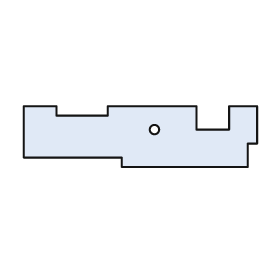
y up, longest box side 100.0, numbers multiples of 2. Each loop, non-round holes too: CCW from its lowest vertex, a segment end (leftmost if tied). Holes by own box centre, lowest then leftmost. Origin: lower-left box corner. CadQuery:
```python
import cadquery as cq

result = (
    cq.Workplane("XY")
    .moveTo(42.0, 0.0)
    .lineTo(96.0, 0.0)
    .lineTo(96.0, 10.0)
    .lineTo(100.0, 10.0)
    .lineTo(100.0, 26.0)
    .lineTo(88.0, 26.0)
    .lineTo(88.0, 16.0)
    .lineTo(74.0, 16.0)
    .lineTo(74.0, 26.0)
    .lineTo(36.0, 26.0)
    .lineTo(36.0, 22.0)
    .lineTo(14.0, 22.0)
    .lineTo(14.0, 26.0)
    .lineTo(0.0, 26.0)
    .lineTo(0.0, 4.0)
    .lineTo(42.0, 4.0)
    .close()
    .moveTo(56.0, 16.0)
    .circle(2.0)
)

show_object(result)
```